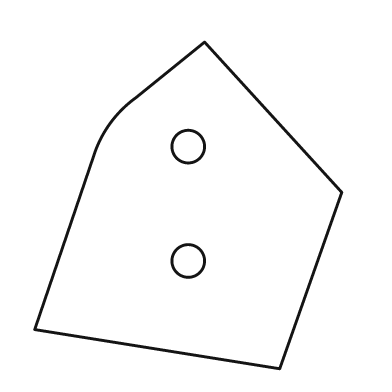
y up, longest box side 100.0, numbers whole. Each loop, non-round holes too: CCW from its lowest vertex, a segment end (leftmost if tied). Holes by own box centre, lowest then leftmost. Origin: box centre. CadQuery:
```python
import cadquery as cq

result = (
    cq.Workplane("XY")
    .moveTo(28.0, -50.0)
    .lineTo(47.0, 4.0)
    .lineTo(5.0, 50.0)
    .lineTo(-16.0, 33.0)
    .threePointArc((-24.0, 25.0), (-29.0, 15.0))
    .lineTo(-47.0, -38.0)
    .close()
    .moveTo(0.0, -17.0)
    .circle(5.0)
    .moveTo(0.0, 18.0)
    .circle(5.0)
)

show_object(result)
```